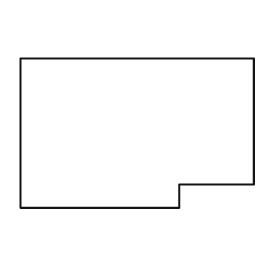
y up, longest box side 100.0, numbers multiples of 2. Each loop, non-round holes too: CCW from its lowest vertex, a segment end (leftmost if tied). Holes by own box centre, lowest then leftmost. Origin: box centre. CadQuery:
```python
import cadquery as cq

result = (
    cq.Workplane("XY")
    .moveTo(-50.0, -32.0)
    .lineTo(18.0, -32.0)
    .lineTo(18.0, -22.0)
    .lineTo(50.0, -22.0)
    .lineTo(50.0, 32.0)
    .lineTo(-50.0, 32.0)
    .close()
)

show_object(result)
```